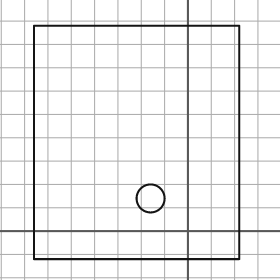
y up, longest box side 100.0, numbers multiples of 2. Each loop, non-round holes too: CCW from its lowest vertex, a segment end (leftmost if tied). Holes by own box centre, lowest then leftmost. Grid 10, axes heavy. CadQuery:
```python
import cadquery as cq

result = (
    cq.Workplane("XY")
    .moveTo(-66.0, -12.0)
    .lineTo(22.0, -12.0)
    .lineTo(22.0, 88.0)
    .lineTo(-66.0, 88.0)
    .close()
    .moveTo(-16.0, 14.0)
    .circle(6.0)
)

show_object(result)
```